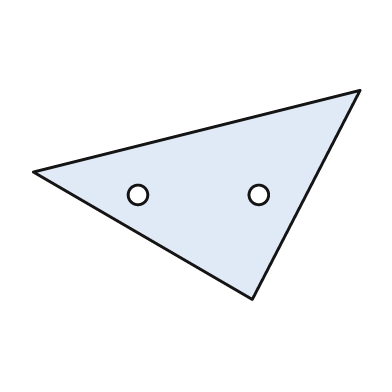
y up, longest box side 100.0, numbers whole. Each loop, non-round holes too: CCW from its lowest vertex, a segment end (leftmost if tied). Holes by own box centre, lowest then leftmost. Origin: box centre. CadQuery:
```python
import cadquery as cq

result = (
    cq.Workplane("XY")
    .moveTo(17.0, -32.0)
    .lineTo(50.0, 32.0)
    .lineTo(-50.0, 7.0)
    .close()
    .moveTo(-18.0, 0.0)
    .circle(3.0)
    .moveTo(19.0, 0.0)
    .circle(3.0)
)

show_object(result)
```